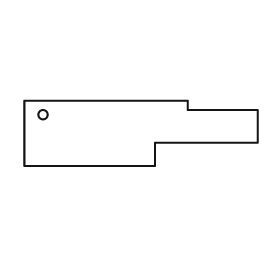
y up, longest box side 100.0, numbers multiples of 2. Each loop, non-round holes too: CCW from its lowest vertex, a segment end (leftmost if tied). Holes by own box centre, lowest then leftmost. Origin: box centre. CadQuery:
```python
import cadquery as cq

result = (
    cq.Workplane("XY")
    .moveTo(-50.0, -14.0)
    .lineTo(6.0, -14.0)
    .lineTo(6.0, -4.0)
    .lineTo(50.0, -4.0)
    .lineTo(50.0, 10.0)
    .lineTo(20.0, 10.0)
    .lineTo(20.0, 14.0)
    .lineTo(-50.0, 14.0)
    .close()
    .moveTo(-42.0, 8.0)
    .circle(2.0)
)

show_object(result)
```